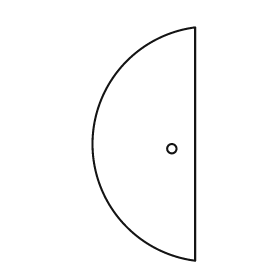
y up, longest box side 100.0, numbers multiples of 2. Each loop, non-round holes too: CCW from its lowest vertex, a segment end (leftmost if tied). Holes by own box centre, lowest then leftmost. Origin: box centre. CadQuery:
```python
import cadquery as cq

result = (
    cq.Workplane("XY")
    .moveTo(22.0, -50.0)
    .lineTo(22.0, 50.0)
    .threePointArc((-22.0, 0.0), (22.0, -50.0))
    .close()
    .moveTo(12.0, -2.0)
    .circle(2.0)
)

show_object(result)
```